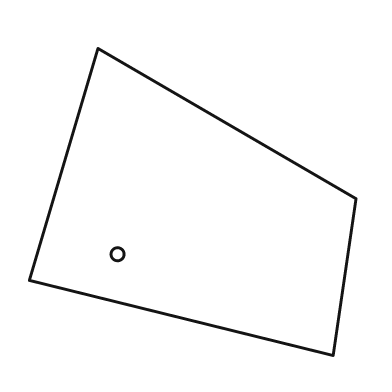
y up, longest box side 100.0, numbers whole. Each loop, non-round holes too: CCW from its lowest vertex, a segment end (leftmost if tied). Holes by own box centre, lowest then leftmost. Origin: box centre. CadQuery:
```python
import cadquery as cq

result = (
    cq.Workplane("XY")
    .moveTo(43.0, -47.0)
    .lineTo(50.0, 1.0)
    .lineTo(-29.0, 47.0)
    .lineTo(-50.0, -24.0)
    .close()
    .moveTo(-23.0, -16.0)
    .circle(2.0)
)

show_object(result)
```